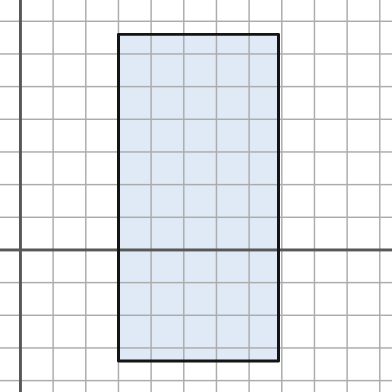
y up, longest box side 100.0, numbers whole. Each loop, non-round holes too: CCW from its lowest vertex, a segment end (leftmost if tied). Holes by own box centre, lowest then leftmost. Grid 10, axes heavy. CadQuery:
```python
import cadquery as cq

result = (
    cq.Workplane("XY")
    .moveTo(30.0, -34.0)
    .lineTo(79.0, -34.0)
    .lineTo(79.0, 66.0)
    .lineTo(30.0, 66.0)
    .close()
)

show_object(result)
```